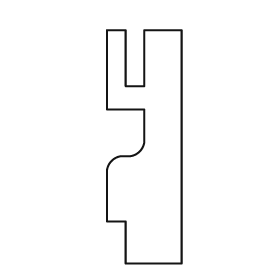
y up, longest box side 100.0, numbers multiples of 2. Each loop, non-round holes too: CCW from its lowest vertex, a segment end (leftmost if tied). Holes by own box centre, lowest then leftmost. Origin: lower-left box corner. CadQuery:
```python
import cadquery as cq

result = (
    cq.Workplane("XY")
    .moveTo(8.0, 0.0)
    .lineTo(32.0, 0.0)
    .lineTo(32.0, 100.0)
    .lineTo(16.0, 100.0)
    .lineTo(16.0, 76.0)
    .lineTo(8.0, 76.0)
    .lineTo(8.0, 100.0)
    .lineTo(0.0, 100.0)
    .lineTo(0.0, 66.0)
    .lineTo(16.0, 66.0)
    .lineTo(16.0, 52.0)
    .threePointArc((14.0, 48.0), (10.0, 46.0))
    .lineTo(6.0, 46.0)
    .threePointArc((2.0, 44.0), (0.0, 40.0))
    .lineTo(0.0, 18.0)
    .lineTo(8.0, 18.0)
    .close()
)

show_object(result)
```